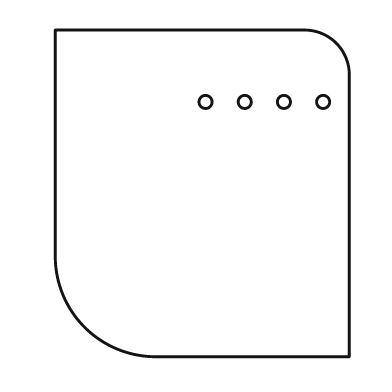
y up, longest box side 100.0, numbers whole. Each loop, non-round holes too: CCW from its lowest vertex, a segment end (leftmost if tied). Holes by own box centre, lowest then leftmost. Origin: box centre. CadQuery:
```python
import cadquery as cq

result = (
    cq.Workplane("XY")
    .moveTo(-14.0, -50.0)
    .lineTo(45.0, -50.0)
    .lineTo(45.0, 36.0)
    .threePointArc((41.0, 46.0), (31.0, 50.0))
    .lineTo(-45.0, 50.0)
    .lineTo(-45.0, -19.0)
    .threePointArc((-36.0, -41.0), (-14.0, -50.0))
    .close()
    .moveTo(1.0, 28.0)
    .circle(2.0)
    .moveTo(13.0, 28.0)
    .circle(2.0)
    .moveTo(25.0, 28.0)
    .circle(2.0)
    .moveTo(37.0, 28.0)
    .circle(2.0)
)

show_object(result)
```